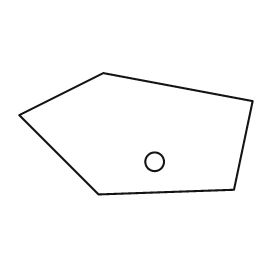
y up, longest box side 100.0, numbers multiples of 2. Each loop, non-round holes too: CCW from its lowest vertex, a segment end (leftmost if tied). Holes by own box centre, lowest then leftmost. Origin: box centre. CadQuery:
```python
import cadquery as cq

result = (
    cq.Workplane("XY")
    .moveTo(-16.0, -26.0)
    .lineTo(42.0, -24.0)
    .lineTo(50.0, 14.0)
    .lineTo(-14.0, 26.0)
    .lineTo(-50.0, 8.0)
    .close()
    .moveTo(8.0, -12.0)
    .circle(4.0)
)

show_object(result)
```